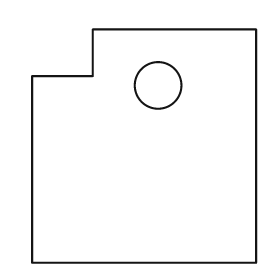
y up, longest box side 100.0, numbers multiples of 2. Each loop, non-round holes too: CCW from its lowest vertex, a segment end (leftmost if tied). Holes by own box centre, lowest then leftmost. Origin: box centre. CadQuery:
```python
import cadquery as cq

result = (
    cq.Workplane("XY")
    .moveTo(-48.0, -50.0)
    .lineTo(48.0, -50.0)
    .lineTo(48.0, 50.0)
    .lineTo(-22.0, 50.0)
    .lineTo(-22.0, 30.0)
    .lineTo(-48.0, 30.0)
    .close()
    .moveTo(6.0, 26.0)
    .circle(10.0)
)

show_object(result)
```